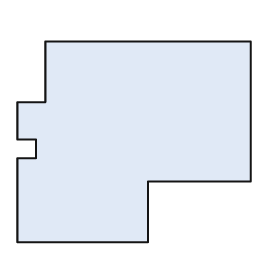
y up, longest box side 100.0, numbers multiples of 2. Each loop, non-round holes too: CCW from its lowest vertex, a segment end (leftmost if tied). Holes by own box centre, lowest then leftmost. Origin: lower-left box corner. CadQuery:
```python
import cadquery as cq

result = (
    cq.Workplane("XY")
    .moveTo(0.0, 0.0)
    .lineTo(56.0, 0.0)
    .lineTo(56.0, 26.0)
    .lineTo(100.0, 26.0)
    .lineTo(100.0, 86.0)
    .lineTo(12.0, 86.0)
    .lineTo(12.0, 60.0)
    .lineTo(0.0, 60.0)
    .lineTo(0.0, 44.0)
    .lineTo(8.0, 44.0)
    .lineTo(8.0, 36.0)
    .lineTo(0.0, 36.0)
    .close()
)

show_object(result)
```